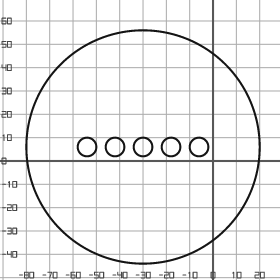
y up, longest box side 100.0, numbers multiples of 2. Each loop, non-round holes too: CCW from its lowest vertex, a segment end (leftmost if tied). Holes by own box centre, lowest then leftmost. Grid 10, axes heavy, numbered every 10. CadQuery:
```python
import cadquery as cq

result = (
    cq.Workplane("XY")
    .moveTo(-30.0, 6.0)
    .circle(50.0)
    .moveTo(-54.0, 6.0)
    .circle(4.0)
    .moveTo(-42.0, 6.0)
    .circle(4.0)
    .moveTo(-30.0, 6.0)
    .circle(4.0)
    .moveTo(-18.0, 6.0)
    .circle(4.0)
    .moveTo(-6.0, 6.0)
    .circle(4.0)
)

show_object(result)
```